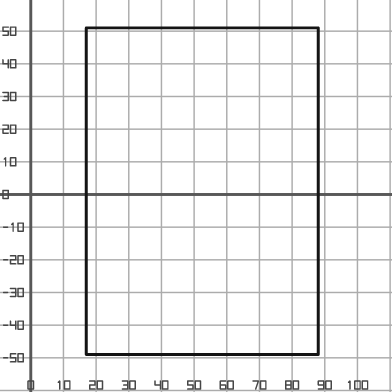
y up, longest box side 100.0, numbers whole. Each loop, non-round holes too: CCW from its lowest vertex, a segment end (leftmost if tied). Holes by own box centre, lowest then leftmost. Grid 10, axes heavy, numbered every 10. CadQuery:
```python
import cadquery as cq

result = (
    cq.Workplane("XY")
    .moveTo(17.0, -49.0)
    .lineTo(88.0, -49.0)
    .lineTo(88.0, 51.0)
    .lineTo(17.0, 51.0)
    .close()
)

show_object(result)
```